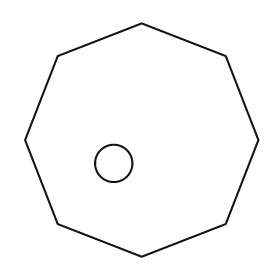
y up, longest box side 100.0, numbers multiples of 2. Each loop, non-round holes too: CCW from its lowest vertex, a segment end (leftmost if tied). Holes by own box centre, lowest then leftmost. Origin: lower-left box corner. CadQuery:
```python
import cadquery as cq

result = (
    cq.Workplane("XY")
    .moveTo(50.0, 0.0)
    .lineTo(86.0, 14.0)
    .lineTo(100.0, 50.0)
    .lineTo(86.0, 86.0)
    .lineTo(50.0, 100.0)
    .lineTo(14.0, 86.0)
    .lineTo(0.0, 50.0)
    .lineTo(14.0, 14.0)
    .close()
    .moveTo(38.0, 40.0)
    .circle(8.0)
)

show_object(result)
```